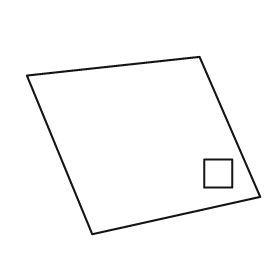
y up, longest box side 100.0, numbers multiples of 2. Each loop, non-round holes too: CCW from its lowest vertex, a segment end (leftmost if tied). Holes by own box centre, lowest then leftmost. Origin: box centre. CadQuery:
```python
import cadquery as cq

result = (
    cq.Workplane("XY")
    .moveTo(-22.0, -38.0)
    .lineTo(50.0, -22.0)
    .lineTo(24.0, 38.0)
    .lineTo(-50.0, 30.0)
    .close()
    .moveTo(26.0, -18.0)
    .lineTo(38.0, -18.0)
    .lineTo(38.0, -6.0)
    .lineTo(26.0, -6.0)
    .close()
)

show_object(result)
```